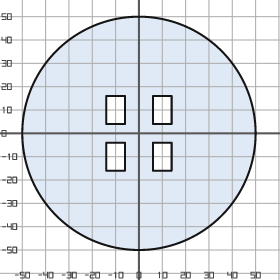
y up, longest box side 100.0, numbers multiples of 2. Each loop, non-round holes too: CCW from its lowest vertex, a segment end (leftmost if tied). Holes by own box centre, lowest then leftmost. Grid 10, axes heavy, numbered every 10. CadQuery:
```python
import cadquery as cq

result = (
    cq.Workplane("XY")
    .moveTo(0.0, 0.0)
    .circle(50.0)
    .moveTo(-14.0, -16.0)
    .lineTo(-6.0, -16.0)
    .lineTo(-6.0, -4.0)
    .lineTo(-14.0, -4.0)
    .close()
    .moveTo(6.0, -16.0)
    .lineTo(14.0, -16.0)
    .lineTo(14.0, -4.0)
    .lineTo(6.0, -4.0)
    .close()
    .moveTo(-14.0, 4.0)
    .lineTo(-6.0, 4.0)
    .lineTo(-6.0, 16.0)
    .lineTo(-14.0, 16.0)
    .close()
    .moveTo(6.0, 4.0)
    .lineTo(14.0, 4.0)
    .lineTo(14.0, 16.0)
    .lineTo(6.0, 16.0)
    .close()
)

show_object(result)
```